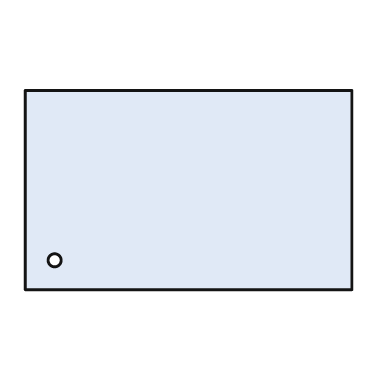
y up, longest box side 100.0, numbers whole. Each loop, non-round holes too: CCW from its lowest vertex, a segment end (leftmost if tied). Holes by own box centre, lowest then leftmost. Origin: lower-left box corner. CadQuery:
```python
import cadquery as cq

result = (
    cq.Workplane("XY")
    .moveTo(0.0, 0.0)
    .lineTo(100.0, 0.0)
    .lineTo(100.0, 61.0)
    .lineTo(0.0, 61.0)
    .close()
    .moveTo(9.0, 9.0)
    .circle(2.0)
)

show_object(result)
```